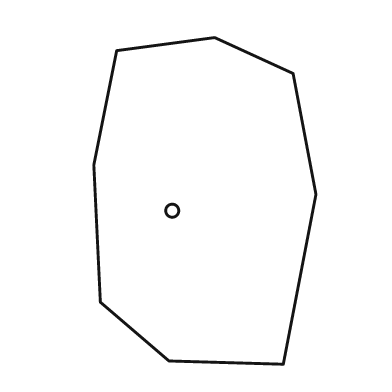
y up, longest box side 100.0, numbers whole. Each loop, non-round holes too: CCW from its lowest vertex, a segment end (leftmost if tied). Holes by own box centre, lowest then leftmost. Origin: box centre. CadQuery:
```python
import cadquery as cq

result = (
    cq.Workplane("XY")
    .moveTo(24.0, -50.0)
    .lineTo(34.0, 2.0)
    .lineTo(27.0, 39.0)
    .lineTo(3.0, 50.0)
    .lineTo(-27.0, 46.0)
    .lineTo(-34.0, 11.0)
    .lineTo(-32.0, -31.0)
    .lineTo(-11.0, -49.0)
    .close()
    .moveTo(-10.0, -3.0)
    .circle(2.0)
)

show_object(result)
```